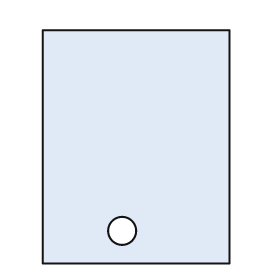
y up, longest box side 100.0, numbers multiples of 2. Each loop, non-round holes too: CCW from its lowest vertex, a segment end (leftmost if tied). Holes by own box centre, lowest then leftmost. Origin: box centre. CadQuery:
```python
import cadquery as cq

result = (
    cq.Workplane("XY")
    .moveTo(-40.0, -50.0)
    .lineTo(40.0, -50.0)
    .lineTo(40.0, 50.0)
    .lineTo(-40.0, 50.0)
    .close()
    .moveTo(-6.0, -36.0)
    .circle(6.0)
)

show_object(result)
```